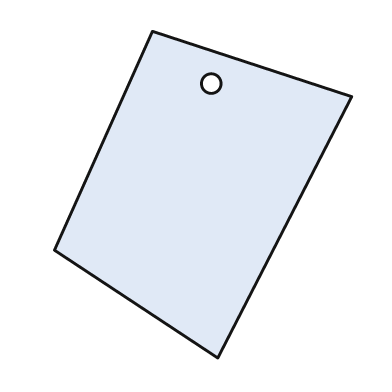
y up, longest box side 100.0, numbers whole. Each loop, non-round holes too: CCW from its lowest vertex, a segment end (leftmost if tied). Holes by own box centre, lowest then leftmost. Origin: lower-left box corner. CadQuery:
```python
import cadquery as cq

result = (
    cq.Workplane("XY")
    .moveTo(50.0, 0.0)
    .lineTo(91.0, 80.0)
    .lineTo(30.0, 100.0)
    .lineTo(0.0, 33.0)
    .close()
    .moveTo(48.0, 84.0)
    .circle(3.0)
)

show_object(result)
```